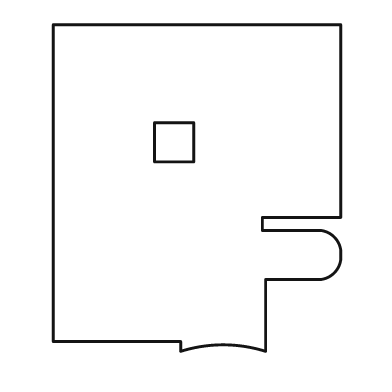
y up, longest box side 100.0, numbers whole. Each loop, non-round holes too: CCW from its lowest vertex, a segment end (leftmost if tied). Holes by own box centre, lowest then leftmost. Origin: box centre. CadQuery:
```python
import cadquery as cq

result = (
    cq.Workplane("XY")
    .moveTo(-5.0, -50.0)
    .threePointArc((8.0, -48.0), (21.0, -50.0))
    .lineTo(21.0, -28.0)
    .lineTo(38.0, -28.0)
    .threePointArc((42.0, -26.0), (44.0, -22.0))
    .lineTo(44.0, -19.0)
    .threePointArc((42.0, -15.0), (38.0, -13.0))
    .lineTo(20.0, -13.0)
    .lineTo(20.0, -9.0)
    .lineTo(44.0, -9.0)
    .lineTo(44.0, 50.0)
    .lineTo(-44.0, 50.0)
    .lineTo(-44.0, -47.0)
    .lineTo(-5.0, -47.0)
    .close()
    .moveTo(-13.0, 8.0)
    .lineTo(-1.0, 8.0)
    .lineTo(-1.0, 20.0)
    .lineTo(-13.0, 20.0)
    .close()
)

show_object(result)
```